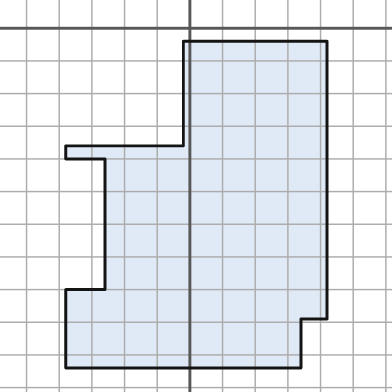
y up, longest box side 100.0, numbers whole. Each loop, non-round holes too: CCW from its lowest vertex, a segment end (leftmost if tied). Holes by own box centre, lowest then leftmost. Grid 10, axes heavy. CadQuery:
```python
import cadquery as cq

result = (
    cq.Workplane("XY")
    .moveTo(-38.0, -104.0)
    .lineTo(34.0, -104.0)
    .lineTo(34.0, -89.0)
    .lineTo(42.0, -89.0)
    .lineTo(42.0, -4.0)
    .lineTo(-2.0, -4.0)
    .lineTo(-2.0, -36.0)
    .lineTo(-38.0, -36.0)
    .lineTo(-38.0, -40.0)
    .lineTo(-26.0, -40.0)
    .lineTo(-26.0, -80.0)
    .lineTo(-38.0, -80.0)
    .close()
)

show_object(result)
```